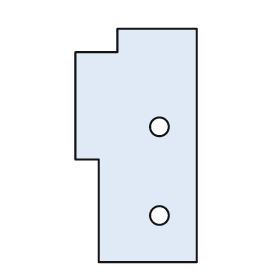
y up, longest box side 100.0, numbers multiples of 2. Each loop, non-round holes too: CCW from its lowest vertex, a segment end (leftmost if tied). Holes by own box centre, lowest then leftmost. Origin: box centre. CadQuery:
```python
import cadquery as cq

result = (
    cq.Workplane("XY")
    .moveTo(-16.0, -50.0)
    .lineTo(26.0, -50.0)
    .lineTo(26.0, 50.0)
    .lineTo(-8.0, 50.0)
    .lineTo(-8.0, 40.0)
    .lineTo(-26.0, 40.0)
    .lineTo(-26.0, -6.0)
    .lineTo(-16.0, -6.0)
    .close()
    .moveTo(10.0, -30.0)
    .circle(4.0)
    .moveTo(10.0, 8.0)
    .circle(4.0)
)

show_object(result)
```